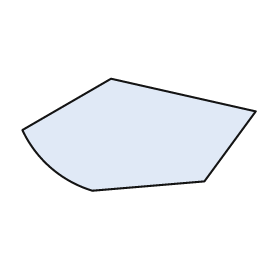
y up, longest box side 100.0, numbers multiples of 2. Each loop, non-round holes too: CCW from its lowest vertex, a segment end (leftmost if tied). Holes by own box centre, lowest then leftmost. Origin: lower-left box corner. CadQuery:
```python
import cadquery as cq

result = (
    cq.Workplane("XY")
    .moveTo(30.0, 0.0)
    .lineTo(78.0, 4.0)
    .lineTo(100.0, 34.0)
    .lineTo(38.0, 48.0)
    .lineTo(0.0, 26.0)
    .threePointArc((12.0, 10.0), (30.0, 0.0))
    .close()
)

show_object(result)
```